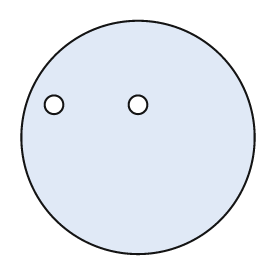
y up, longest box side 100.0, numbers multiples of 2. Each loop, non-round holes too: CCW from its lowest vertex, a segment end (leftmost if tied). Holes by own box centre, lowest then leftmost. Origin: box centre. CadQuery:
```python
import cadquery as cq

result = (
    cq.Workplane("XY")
    .moveTo(0.0, 0.0)
    .circle(50.0)
    .moveTo(-36.0, 14.0)
    .circle(4.0)
    .moveTo(0.0, 14.0)
    .circle(4.0)
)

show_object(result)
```